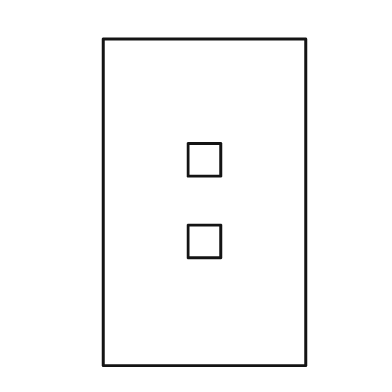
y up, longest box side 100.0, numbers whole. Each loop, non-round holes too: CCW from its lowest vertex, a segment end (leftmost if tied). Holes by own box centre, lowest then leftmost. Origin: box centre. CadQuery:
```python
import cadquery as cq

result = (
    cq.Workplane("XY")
    .moveTo(-31.0, -50.0)
    .lineTo(31.0, -50.0)
    .lineTo(31.0, 50.0)
    .lineTo(-31.0, 50.0)
    .close()
    .moveTo(-5.0, -17.0)
    .lineTo(5.0, -17.0)
    .lineTo(5.0, -7.0)
    .lineTo(-5.0, -7.0)
    .close()
    .moveTo(-5.0, 8.0)
    .lineTo(5.0, 8.0)
    .lineTo(5.0, 18.0)
    .lineTo(-5.0, 18.0)
    .close()
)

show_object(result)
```